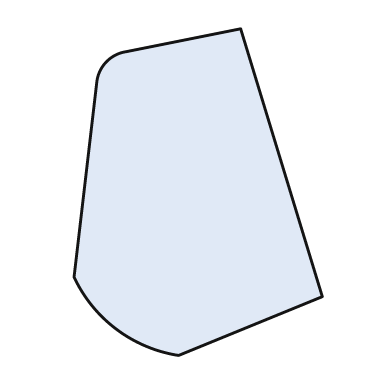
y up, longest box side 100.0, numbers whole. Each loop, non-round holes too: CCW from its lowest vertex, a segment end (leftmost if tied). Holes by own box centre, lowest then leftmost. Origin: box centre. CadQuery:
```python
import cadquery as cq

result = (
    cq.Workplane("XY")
    .moveTo(-6.0, -50.0)
    .lineTo(38.0, -32.0)
    .lineTo(13.0, 50.0)
    .lineTo(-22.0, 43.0)
    .threePointArc((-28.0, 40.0), (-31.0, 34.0))
    .lineTo(-38.0, -26.0)
    .threePointArc((-25.0, -42.0), (-6.0, -50.0))
    .close()
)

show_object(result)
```